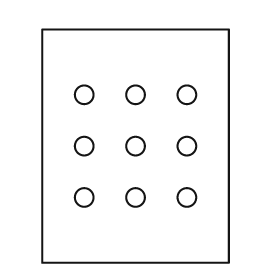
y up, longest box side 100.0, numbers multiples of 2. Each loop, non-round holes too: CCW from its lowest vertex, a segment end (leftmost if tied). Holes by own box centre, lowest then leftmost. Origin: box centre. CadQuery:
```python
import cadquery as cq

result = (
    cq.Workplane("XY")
    .moveTo(-40.0, -50.0)
    .lineTo(40.0, -50.0)
    .lineTo(40.0, 50.0)
    .lineTo(-40.0, 50.0)
    .close()
    .moveTo(-22.0, -22.0)
    .circle(4.0)
    .moveTo(0.0, -22.0)
    .circle(4.0)
    .moveTo(22.0, -22.0)
    .circle(4.0)
    .moveTo(-22.0, 0.0)
    .circle(4.0)
    .moveTo(0.0, 0.0)
    .circle(4.0)
    .moveTo(22.0, 0.0)
    .circle(4.0)
    .moveTo(-22.0, 22.0)
    .circle(4.0)
    .moveTo(0.0, 22.0)
    .circle(4.0)
    .moveTo(22.0, 22.0)
    .circle(4.0)
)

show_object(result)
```